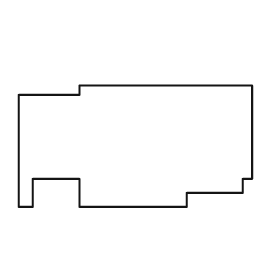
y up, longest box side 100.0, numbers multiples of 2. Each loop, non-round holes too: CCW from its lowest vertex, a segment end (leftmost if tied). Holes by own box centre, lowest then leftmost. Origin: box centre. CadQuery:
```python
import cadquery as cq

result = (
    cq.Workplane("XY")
    .moveTo(-50.0, -26.0)
    .lineTo(-44.0, -26.0)
    .lineTo(-44.0, -14.0)
    .lineTo(-24.0, -14.0)
    .lineTo(-24.0, -26.0)
    .lineTo(22.0, -26.0)
    .lineTo(22.0, -20.0)
    .lineTo(46.0, -20.0)
    .lineTo(46.0, -14.0)
    .lineTo(50.0, -14.0)
    .lineTo(50.0, 26.0)
    .lineTo(-24.0, 26.0)
    .lineTo(-24.0, 22.0)
    .lineTo(-50.0, 22.0)
    .close()
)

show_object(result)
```